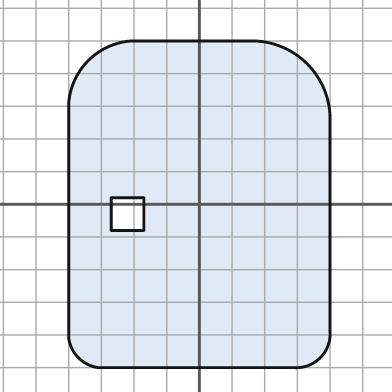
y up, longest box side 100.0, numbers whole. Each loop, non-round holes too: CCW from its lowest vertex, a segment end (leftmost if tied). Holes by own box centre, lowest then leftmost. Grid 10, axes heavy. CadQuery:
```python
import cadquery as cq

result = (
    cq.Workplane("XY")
    .moveTo(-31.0, -50.0)
    .lineTo(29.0, -50.0)
    .threePointArc((37.0, -47.0), (40.0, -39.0))
    .lineTo(40.0, 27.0)
    .threePointArc((33.0, 43.0), (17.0, 50.0))
    .lineTo(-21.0, 50.0)
    .threePointArc((-34.0, 44.0), (-40.0, 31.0))
    .lineTo(-40.0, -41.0)
    .threePointArc((-37.0, -47.0), (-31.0, -50.0))
    .close()
    .moveTo(-27.0, -8.0)
    .lineTo(-17.0, -8.0)
    .lineTo(-17.0, 2.0)
    .lineTo(-27.0, 2.0)
    .close()
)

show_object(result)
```